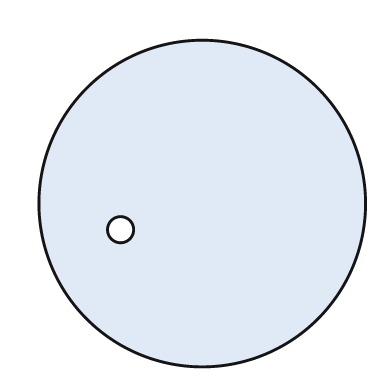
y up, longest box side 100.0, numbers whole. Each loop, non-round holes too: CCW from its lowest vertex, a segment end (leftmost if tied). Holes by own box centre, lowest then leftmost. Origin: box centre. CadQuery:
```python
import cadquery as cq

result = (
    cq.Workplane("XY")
    .moveTo(0.0, 0.0)
    .circle(50.0)
    .moveTo(-25.0, -8.0)
    .circle(4.0)
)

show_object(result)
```